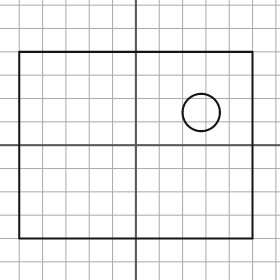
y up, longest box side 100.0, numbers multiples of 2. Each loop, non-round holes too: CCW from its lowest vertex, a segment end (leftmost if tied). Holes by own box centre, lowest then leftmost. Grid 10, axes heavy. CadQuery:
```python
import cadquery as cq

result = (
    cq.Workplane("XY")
    .moveTo(-50.0, -40.0)
    .lineTo(50.0, -40.0)
    .lineTo(50.0, 40.0)
    .lineTo(-50.0, 40.0)
    .close()
    .moveTo(28.0, 14.0)
    .circle(8.0)
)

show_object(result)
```